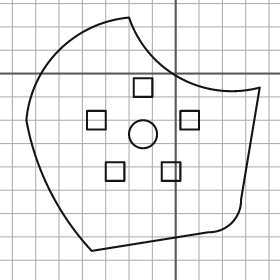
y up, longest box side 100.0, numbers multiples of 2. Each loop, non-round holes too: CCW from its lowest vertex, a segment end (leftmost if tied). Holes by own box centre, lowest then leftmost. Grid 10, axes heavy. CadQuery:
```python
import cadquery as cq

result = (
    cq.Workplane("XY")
    .moveTo(-36.0, -76.0)
    .lineTo(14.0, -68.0)
    .threePointArc((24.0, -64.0), (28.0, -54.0))
    .lineTo(36.0, -6.0)
    .threePointArc((2.0, -2.0), (-20.0, 24.0))
    .threePointArc((-50.0, 10.0), (-64.0, -20.0))
    .threePointArc((-54.0, -50.0), (-36.0, -76.0))
    .close()
    .moveTo(-30.0, -46.0)
    .lineTo(-22.0, -46.0)
    .lineTo(-22.0, -38.0)
    .lineTo(-30.0, -38.0)
    .close()
    .moveTo(-6.0, -46.0)
    .lineTo(2.0, -46.0)
    .lineTo(2.0, -38.0)
    .lineTo(-6.0, -38.0)
    .close()
    .moveTo(-14.0, -26.0)
    .circle(6.0)
    .moveTo(-38.0, -24.0)
    .lineTo(-30.0, -24.0)
    .lineTo(-30.0, -16.0)
    .lineTo(-38.0, -16.0)
    .close()
    .moveTo(2.0, -24.0)
    .lineTo(10.0, -24.0)
    .lineTo(10.0, -16.0)
    .lineTo(2.0, -16.0)
    .close()
    .moveTo(-18.0, -10.0)
    .lineTo(-10.0, -10.0)
    .lineTo(-10.0, -2.0)
    .lineTo(-18.0, -2.0)
    .close()
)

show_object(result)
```